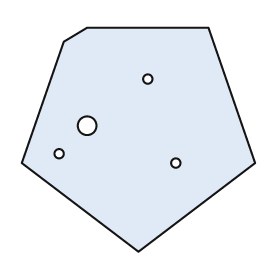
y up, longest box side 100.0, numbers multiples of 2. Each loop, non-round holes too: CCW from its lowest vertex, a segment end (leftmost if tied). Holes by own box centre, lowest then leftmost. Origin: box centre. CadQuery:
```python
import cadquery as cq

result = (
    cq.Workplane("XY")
    .moveTo(0.0, -48.0)
    .lineTo(50.0, -10.0)
    .lineTo(30.0, 48.0)
    .lineTo(-22.0, 48.0)
    .lineTo(-32.0, 42.0)
    .lineTo(-50.0, -10.0)
    .close()
    .moveTo(16.0, -10.0)
    .circle(2.0)
    .moveTo(-34.0, -6.0)
    .circle(2.0)
    .moveTo(-22.0, 6.0)
    .circle(4.0)
    .moveTo(4.0, 26.0)
    .circle(2.0)
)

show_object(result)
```